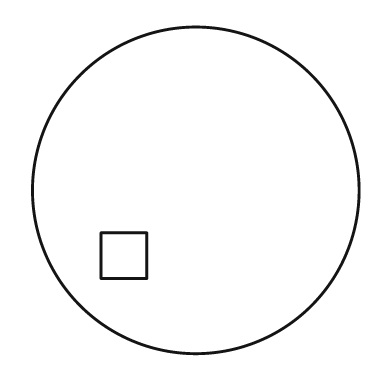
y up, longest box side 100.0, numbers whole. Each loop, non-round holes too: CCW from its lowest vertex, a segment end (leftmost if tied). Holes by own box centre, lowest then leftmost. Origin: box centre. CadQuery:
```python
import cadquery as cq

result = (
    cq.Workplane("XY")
    .moveTo(0.0, 0.0)
    .circle(50.0)
    .moveTo(-29.0, -27.0)
    .lineTo(-15.0, -27.0)
    .lineTo(-15.0, -13.0)
    .lineTo(-29.0, -13.0)
    .close()
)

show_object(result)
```